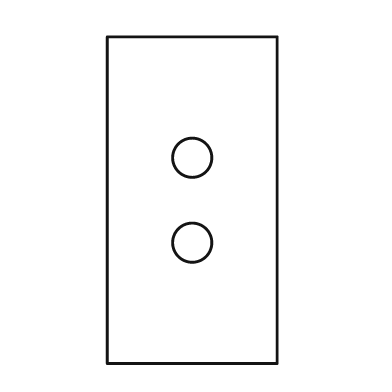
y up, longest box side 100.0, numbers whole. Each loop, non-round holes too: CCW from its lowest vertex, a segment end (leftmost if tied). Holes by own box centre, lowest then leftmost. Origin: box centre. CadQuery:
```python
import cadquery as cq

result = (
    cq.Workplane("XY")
    .moveTo(-26.0, -50.0)
    .lineTo(26.0, -50.0)
    .lineTo(26.0, 50.0)
    .lineTo(-26.0, 50.0)
    .close()
    .moveTo(0.0, -13.0)
    .circle(6.0)
    .moveTo(0.0, 13.0)
    .circle(6.0)
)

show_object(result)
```